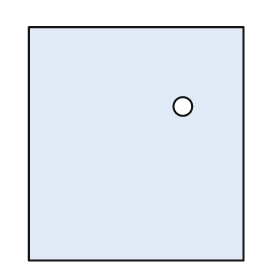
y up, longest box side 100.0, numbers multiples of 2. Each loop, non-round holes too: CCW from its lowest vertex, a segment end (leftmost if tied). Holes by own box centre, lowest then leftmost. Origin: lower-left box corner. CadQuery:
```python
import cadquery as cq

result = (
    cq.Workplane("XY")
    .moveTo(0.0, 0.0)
    .lineTo(92.0, 0.0)
    .lineTo(92.0, 100.0)
    .lineTo(0.0, 100.0)
    .close()
    .moveTo(66.0, 66.0)
    .circle(4.0)
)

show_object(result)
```